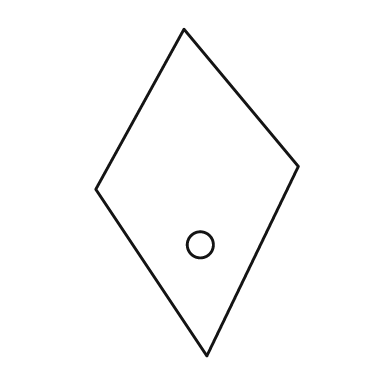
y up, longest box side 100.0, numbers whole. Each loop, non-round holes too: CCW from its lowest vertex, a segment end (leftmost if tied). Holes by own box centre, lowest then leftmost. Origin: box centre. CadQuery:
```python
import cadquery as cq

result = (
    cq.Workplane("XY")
    .moveTo(3.0, -50.0)
    .lineTo(31.0, 8.0)
    .lineTo(-4.0, 50.0)
    .lineTo(-31.0, 1.0)
    .close()
    .moveTo(1.0, -16.0)
    .circle(4.0)
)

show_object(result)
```